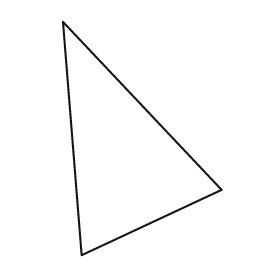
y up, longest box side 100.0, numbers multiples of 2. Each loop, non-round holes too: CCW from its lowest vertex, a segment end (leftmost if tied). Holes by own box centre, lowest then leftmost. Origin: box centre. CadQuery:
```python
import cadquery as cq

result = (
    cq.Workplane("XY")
    .moveTo(-26.0, -50.0)
    .lineTo(34.0, -22.0)
    .lineTo(-34.0, 50.0)
    .close()
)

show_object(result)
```